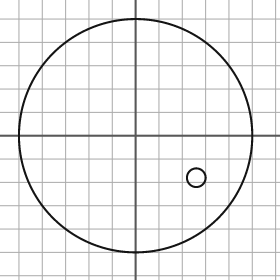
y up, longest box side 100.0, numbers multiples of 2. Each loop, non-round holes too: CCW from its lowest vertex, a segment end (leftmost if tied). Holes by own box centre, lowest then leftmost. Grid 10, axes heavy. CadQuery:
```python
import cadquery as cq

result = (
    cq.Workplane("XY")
    .moveTo(0.0, 0.0)
    .circle(50.0)
    .moveTo(26.0, -18.0)
    .circle(4.0)
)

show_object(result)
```